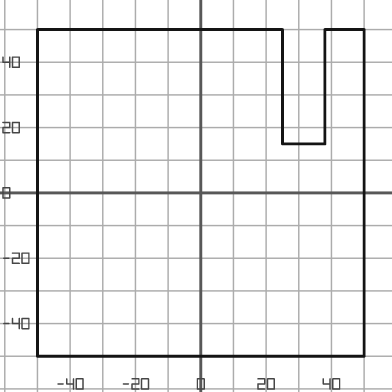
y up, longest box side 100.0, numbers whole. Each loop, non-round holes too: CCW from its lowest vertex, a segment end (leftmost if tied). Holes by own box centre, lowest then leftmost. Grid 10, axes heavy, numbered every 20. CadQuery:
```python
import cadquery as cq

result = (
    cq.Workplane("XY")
    .moveTo(-50.0, -50.0)
    .lineTo(50.0, -50.0)
    .lineTo(50.0, 50.0)
    .lineTo(38.0, 50.0)
    .lineTo(38.0, 15.0)
    .lineTo(25.0, 15.0)
    .lineTo(25.0, 50.0)
    .lineTo(-50.0, 50.0)
    .close()
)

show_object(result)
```